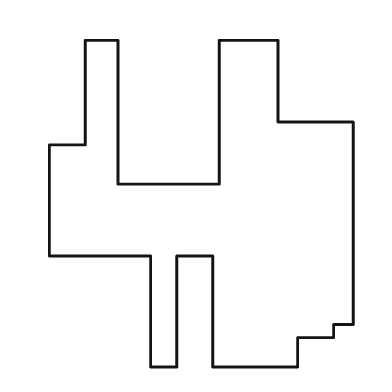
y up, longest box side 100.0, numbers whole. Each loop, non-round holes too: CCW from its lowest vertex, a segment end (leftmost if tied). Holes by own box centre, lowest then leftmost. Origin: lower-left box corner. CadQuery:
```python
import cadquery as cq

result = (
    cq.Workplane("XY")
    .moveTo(31.0, 0.0)
    .lineTo(39.0, 0.0)
    .lineTo(39.0, 34.0)
    .lineTo(50.0, 34.0)
    .lineTo(50.0, 0.0)
    .lineTo(76.0, 0.0)
    .lineTo(76.0, 9.0)
    .lineTo(87.0, 9.0)
    .lineTo(87.0, 13.0)
    .lineTo(93.0, 13.0)
    .lineTo(93.0, 75.0)
    .lineTo(70.0, 75.0)
    .lineTo(70.0, 100.0)
    .lineTo(52.0, 100.0)
    .lineTo(52.0, 56.0)
    .lineTo(21.0, 56.0)
    .lineTo(21.0, 100.0)
    .lineTo(11.0, 100.0)
    .lineTo(11.0, 68.0)
    .lineTo(0.0, 68.0)
    .lineTo(0.0, 34.0)
    .lineTo(31.0, 34.0)
    .close()
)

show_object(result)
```